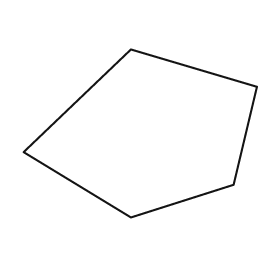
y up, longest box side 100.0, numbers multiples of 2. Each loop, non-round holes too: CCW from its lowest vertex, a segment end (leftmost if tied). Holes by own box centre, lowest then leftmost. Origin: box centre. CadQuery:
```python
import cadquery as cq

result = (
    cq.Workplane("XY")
    .moveTo(-4.0, -36.0)
    .lineTo(40.0, -22.0)
    .lineTo(50.0, 20.0)
    .lineTo(-4.0, 36.0)
    .lineTo(-50.0, -8.0)
    .close()
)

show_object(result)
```